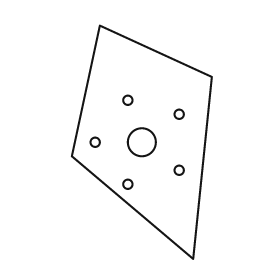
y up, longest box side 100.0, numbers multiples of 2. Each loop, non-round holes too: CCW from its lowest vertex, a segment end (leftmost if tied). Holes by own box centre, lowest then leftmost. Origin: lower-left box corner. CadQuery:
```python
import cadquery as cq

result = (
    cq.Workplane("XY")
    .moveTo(52.0, 0.0)
    .lineTo(60.0, 78.0)
    .lineTo(12.0, 100.0)
    .lineTo(0.0, 44.0)
    .close()
    .moveTo(24.0, 32.0)
    .circle(2.0)
    .moveTo(46.0, 38.0)
    .circle(2.0)
    .moveTo(10.0, 50.0)
    .circle(2.0)
    .moveTo(30.0, 50.0)
    .circle(6.0)
    .moveTo(46.0, 62.0)
    .circle(2.0)
    .moveTo(24.0, 68.0)
    .circle(2.0)
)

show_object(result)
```